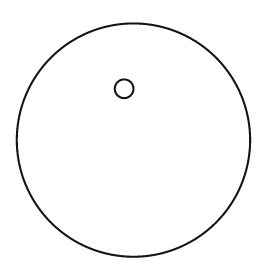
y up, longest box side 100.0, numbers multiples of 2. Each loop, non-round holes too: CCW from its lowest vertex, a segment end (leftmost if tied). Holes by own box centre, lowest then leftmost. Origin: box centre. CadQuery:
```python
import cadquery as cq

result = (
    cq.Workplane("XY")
    .moveTo(0.0, 0.0)
    .circle(50.0)
    .moveTo(-4.0, 22.0)
    .circle(4.0)
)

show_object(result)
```